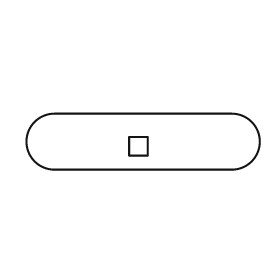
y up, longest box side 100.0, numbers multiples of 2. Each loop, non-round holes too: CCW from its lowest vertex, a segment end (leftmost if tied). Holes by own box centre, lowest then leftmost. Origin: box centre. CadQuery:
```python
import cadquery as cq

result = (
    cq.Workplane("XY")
    .moveTo(-38.0, -12.0)
    .lineTo(38.0, -12.0)
    .threePointArc((50.0, 0.0), (38.0, 12.0))
    .lineTo(-38.0, 12.0)
    .threePointArc((-50.0, 0.0), (-38.0, -12.0))
    .close()
    .moveTo(-6.0, -6.0)
    .lineTo(2.0, -6.0)
    .lineTo(2.0, 2.0)
    .lineTo(-6.0, 2.0)
    .close()
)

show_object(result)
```